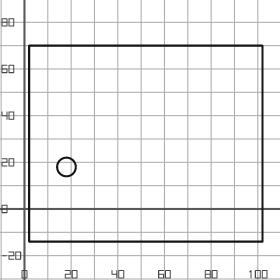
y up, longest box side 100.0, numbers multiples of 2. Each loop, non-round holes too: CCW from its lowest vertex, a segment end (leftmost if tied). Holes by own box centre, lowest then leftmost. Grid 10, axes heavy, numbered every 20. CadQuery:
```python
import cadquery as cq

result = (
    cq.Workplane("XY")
    .moveTo(2.0, -14.0)
    .lineTo(102.0, -14.0)
    .lineTo(102.0, 70.0)
    .lineTo(2.0, 70.0)
    .close()
    .moveTo(18.0, 18.0)
    .circle(4.0)
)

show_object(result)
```